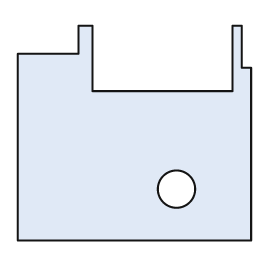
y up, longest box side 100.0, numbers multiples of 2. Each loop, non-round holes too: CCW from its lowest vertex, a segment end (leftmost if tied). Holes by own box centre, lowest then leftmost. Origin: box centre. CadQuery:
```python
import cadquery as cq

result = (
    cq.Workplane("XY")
    .moveTo(-50.0, -46.0)
    .lineTo(50.0, -46.0)
    .lineTo(50.0, 28.0)
    .lineTo(46.0, 28.0)
    .lineTo(46.0, 46.0)
    .lineTo(42.0, 46.0)
    .lineTo(42.0, 18.0)
    .lineTo(-18.0, 18.0)
    .lineTo(-18.0, 46.0)
    .lineTo(-24.0, 46.0)
    .lineTo(-24.0, 34.0)
    .lineTo(-50.0, 34.0)
    .close()
    .moveTo(18.0, -24.0)
    .circle(8.0)
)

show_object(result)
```